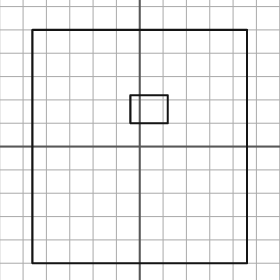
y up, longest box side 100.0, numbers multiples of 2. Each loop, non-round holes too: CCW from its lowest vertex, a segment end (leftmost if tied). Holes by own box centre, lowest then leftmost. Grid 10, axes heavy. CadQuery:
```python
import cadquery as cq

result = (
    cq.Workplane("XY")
    .moveTo(-46.0, -50.0)
    .lineTo(46.0, -50.0)
    .lineTo(46.0, 50.0)
    .lineTo(-46.0, 50.0)
    .close()
    .moveTo(-4.0, 10.0)
    .lineTo(12.0, 10.0)
    .lineTo(12.0, 22.0)
    .lineTo(-4.0, 22.0)
    .close()
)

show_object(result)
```